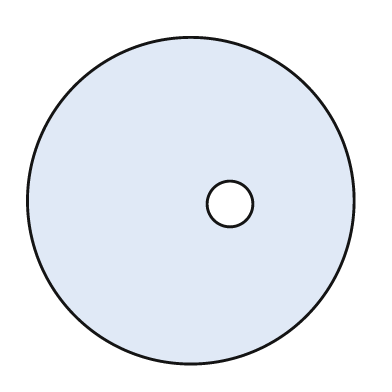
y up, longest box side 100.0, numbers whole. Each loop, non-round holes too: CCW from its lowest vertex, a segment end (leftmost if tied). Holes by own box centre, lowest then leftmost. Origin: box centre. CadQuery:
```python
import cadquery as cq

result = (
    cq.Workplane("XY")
    .moveTo(0.0, 0.0)
    .circle(50.0)
    .moveTo(12.0, -1.0)
    .circle(7.0)
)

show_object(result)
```